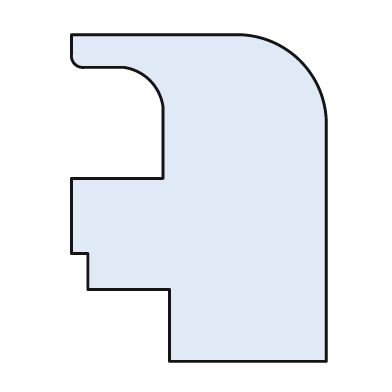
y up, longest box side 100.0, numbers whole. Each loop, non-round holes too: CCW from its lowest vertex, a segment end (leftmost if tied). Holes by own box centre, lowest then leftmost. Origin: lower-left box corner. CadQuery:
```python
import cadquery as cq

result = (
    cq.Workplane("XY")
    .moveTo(30.0, 0.0)
    .lineTo(78.0, 0.0)
    .lineTo(78.0, 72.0)
    .threePointArc((70.0, 92.0), (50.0, 100.0))
    .lineTo(0.0, 100.0)
    .lineTo(0.0, 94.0)
    .threePointArc((1.0, 91.0), (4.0, 90.0))
    .lineTo(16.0, 90.0)
    .threePointArc((24.0, 86.0), (28.0, 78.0))
    .lineTo(28.0, 56.0)
    .lineTo(0.0, 56.0)
    .lineTo(0.0, 33.0)
    .lineTo(5.0, 33.0)
    .lineTo(5.0, 22.0)
    .lineTo(30.0, 22.0)
    .close()
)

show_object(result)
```